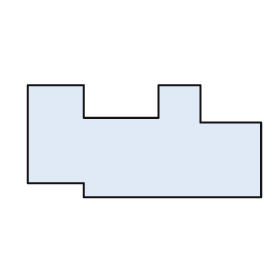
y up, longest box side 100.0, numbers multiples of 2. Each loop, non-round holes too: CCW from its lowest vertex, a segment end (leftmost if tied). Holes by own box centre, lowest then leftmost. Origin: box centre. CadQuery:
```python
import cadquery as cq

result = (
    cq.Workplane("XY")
    .moveTo(-26.0, -24.0)
    .lineTo(50.0, -24.0)
    .lineTo(50.0, 8.0)
    .lineTo(24.0, 8.0)
    .lineTo(24.0, 24.0)
    .lineTo(6.0, 24.0)
    .lineTo(6.0, 10.0)
    .lineTo(-26.0, 10.0)
    .lineTo(-26.0, 24.0)
    .lineTo(-50.0, 24.0)
    .lineTo(-50.0, -18.0)
    .lineTo(-26.0, -18.0)
    .close()
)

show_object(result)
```